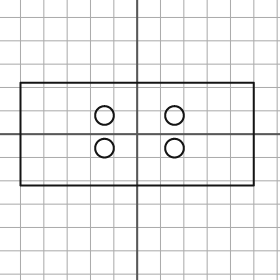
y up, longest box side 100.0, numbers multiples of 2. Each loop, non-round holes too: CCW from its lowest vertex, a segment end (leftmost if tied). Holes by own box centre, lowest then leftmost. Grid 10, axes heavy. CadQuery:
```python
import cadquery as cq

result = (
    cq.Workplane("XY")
    .moveTo(-50.0, -22.0)
    .lineTo(50.0, -22.0)
    .lineTo(50.0, 22.0)
    .lineTo(-50.0, 22.0)
    .close()
    .moveTo(-14.0, -6.0)
    .circle(4.0)
    .moveTo(16.0, -6.0)
    .circle(4.0)
    .moveTo(-14.0, 8.0)
    .circle(4.0)
    .moveTo(16.0, 8.0)
    .circle(4.0)
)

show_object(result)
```